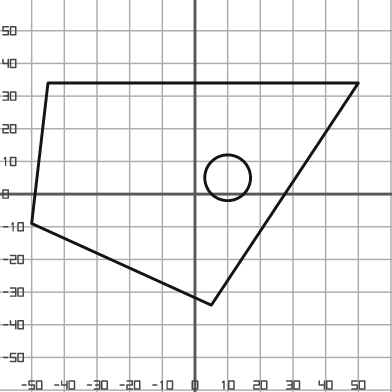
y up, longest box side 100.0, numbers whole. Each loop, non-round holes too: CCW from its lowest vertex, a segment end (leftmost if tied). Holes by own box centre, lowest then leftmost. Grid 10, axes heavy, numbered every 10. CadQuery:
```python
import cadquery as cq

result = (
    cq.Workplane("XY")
    .moveTo(5.0, -34.0)
    .lineTo(50.0, 34.0)
    .lineTo(-45.0, 34.0)
    .lineTo(-50.0, -9.0)
    .close()
    .moveTo(10.0, 5.0)
    .circle(7.0)
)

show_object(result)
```